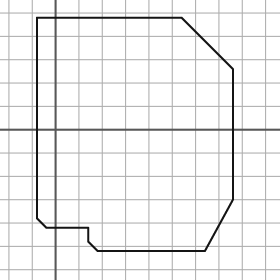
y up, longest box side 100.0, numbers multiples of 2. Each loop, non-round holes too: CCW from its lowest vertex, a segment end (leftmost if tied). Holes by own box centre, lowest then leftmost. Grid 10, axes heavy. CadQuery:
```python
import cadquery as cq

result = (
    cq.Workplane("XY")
    .moveTo(18.0, -52.0)
    .lineTo(64.0, -52.0)
    .lineTo(76.0, -30.0)
    .lineTo(76.0, 26.0)
    .lineTo(54.0, 48.0)
    .lineTo(-8.0, 48.0)
    .lineTo(-8.0, -38.0)
    .lineTo(-4.0, -42.0)
    .lineTo(14.0, -42.0)
    .lineTo(14.0, -48.0)
    .close()
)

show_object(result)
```